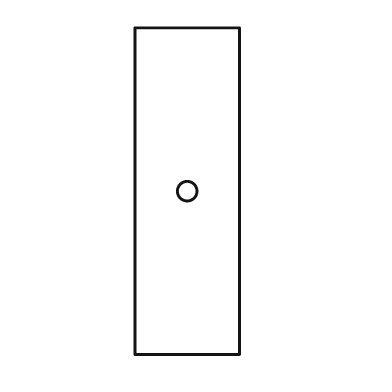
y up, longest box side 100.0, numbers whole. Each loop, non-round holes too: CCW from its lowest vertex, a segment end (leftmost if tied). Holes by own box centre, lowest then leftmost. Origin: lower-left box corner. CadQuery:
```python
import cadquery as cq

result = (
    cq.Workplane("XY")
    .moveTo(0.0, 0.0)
    .lineTo(32.0, 0.0)
    .lineTo(32.0, 100.0)
    .lineTo(0.0, 100.0)
    .close()
    .moveTo(16.0, 50.0)
    .circle(3.0)
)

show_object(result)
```